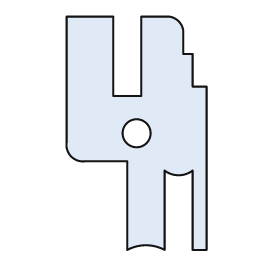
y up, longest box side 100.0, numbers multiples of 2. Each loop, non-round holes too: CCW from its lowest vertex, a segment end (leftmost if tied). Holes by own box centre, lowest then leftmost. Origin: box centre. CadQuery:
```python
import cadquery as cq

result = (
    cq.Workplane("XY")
    .moveTo(-4.0, -50.0)
    .threePointArc((4.0, -48.0), (12.0, -50.0))
    .lineTo(12.0, -16.0)
    .threePointArc((18.0, -18.0), (24.0, -16.0))
    .lineTo(24.0, -50.0)
    .lineTo(30.0, -50.0)
    .lineTo(30.0, 20.0)
    .lineTo(24.0, 20.0)
    .lineTo(24.0, 34.0)
    .lineTo(20.0, 34.0)
    .lineTo(20.0, 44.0)
    .threePointArc((18.0, 48.0), (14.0, 50.0))
    .lineTo(2.0, 50.0)
    .lineTo(2.0, 16.0)
    .lineTo(-10.0, 16.0)
    .lineTo(-10.0, 50.0)
    .lineTo(-30.0, 50.0)
    .lineTo(-30.0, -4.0)
    .threePointArc((-28.0, -10.0), (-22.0, -12.0))
    .lineTo(-4.0, -12.0)
    .close()
    .moveTo(0.0, 0.0)
    .circle(6.0)
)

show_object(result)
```